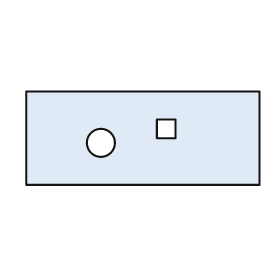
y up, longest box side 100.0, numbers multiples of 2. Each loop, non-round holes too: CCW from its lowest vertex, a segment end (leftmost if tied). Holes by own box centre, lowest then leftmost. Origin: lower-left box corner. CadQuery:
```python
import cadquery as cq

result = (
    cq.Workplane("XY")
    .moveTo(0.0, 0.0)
    .lineTo(100.0, 0.0)
    .lineTo(100.0, 40.0)
    .lineTo(0.0, 40.0)
    .close()
    .moveTo(32.0, 18.0)
    .circle(6.0)
    .moveTo(56.0, 20.0)
    .lineTo(64.0, 20.0)
    .lineTo(64.0, 28.0)
    .lineTo(56.0, 28.0)
    .close()
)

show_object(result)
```